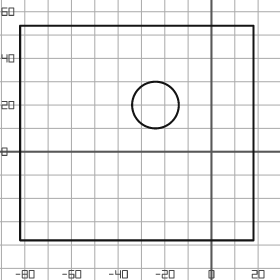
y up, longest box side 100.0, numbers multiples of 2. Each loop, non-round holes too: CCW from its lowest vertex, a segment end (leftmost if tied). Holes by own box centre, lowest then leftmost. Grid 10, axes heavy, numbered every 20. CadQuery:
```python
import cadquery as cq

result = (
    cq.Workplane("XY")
    .moveTo(-82.0, -38.0)
    .lineTo(18.0, -38.0)
    .lineTo(18.0, 54.0)
    .lineTo(-82.0, 54.0)
    .close()
    .moveTo(-24.0, 20.0)
    .circle(10.0)
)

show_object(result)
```